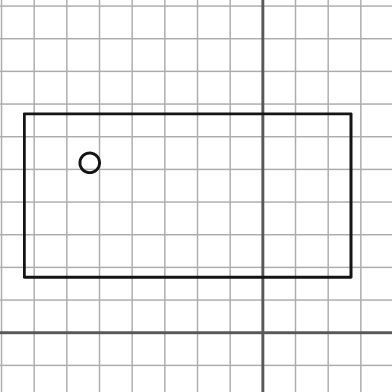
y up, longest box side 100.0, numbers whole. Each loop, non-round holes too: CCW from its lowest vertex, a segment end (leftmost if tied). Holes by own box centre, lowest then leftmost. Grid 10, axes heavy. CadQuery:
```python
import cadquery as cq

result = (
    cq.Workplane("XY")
    .moveTo(-73.0, 17.0)
    .lineTo(27.0, 17.0)
    .lineTo(27.0, 67.0)
    .lineTo(-73.0, 67.0)
    .close()
    .moveTo(-53.0, 52.0)
    .circle(3.0)
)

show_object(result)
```